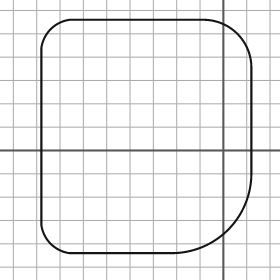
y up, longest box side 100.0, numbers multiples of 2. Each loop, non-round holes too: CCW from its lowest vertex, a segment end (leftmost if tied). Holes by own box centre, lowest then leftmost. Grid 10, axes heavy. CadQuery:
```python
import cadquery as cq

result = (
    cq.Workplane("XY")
    .moveTo(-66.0, -44.0)
    .lineTo(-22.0, -44.0)
    .threePointArc((2.0, -34.0), (12.0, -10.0))
    .lineTo(12.0, 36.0)
    .threePointArc((6.0, 50.0), (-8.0, 56.0))
    .lineTo(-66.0, 56.0)
    .threePointArc((-74.0, 52.0), (-78.0, 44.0))
    .lineTo(-78.0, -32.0)
    .threePointArc((-74.0, -40.0), (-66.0, -44.0))
    .close()
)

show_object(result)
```